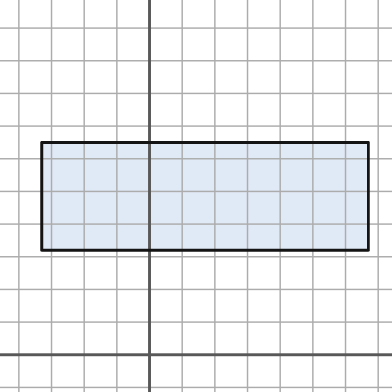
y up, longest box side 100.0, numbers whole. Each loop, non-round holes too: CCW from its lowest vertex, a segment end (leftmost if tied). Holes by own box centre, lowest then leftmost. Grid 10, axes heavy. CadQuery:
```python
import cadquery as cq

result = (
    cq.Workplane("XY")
    .moveTo(-33.0, 32.0)
    .lineTo(67.0, 32.0)
    .lineTo(67.0, 65.0)
    .lineTo(-33.0, 65.0)
    .close()
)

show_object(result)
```